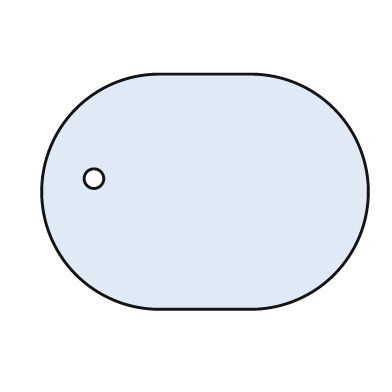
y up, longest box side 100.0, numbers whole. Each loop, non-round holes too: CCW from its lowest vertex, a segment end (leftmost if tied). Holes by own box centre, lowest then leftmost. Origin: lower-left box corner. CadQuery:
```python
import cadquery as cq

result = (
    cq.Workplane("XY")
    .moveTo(36.0, 0.0)
    .lineTo(64.0, 0.0)
    .threePointArc((100.0, 36.0), (64.0, 72.0))
    .lineTo(36.0, 72.0)
    .threePointArc((0.0, 36.0), (36.0, 0.0))
    .close()
    .moveTo(16.0, 40.0)
    .circle(3.0)
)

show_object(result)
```